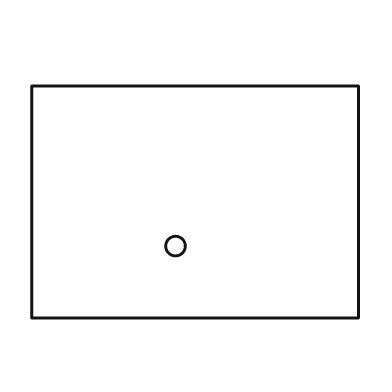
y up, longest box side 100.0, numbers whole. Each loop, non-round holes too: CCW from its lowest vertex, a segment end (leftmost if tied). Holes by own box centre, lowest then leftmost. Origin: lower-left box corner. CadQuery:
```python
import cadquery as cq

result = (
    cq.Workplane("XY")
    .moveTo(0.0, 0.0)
    .lineTo(100.0, 0.0)
    .lineTo(100.0, 71.0)
    .lineTo(0.0, 71.0)
    .close()
    .moveTo(44.0, 22.0)
    .circle(3.0)
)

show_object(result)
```